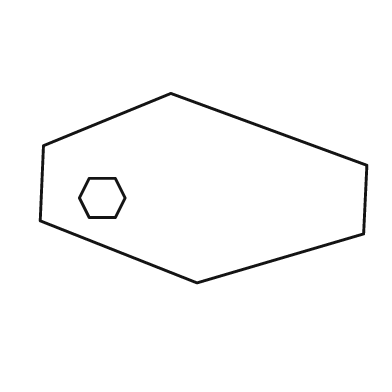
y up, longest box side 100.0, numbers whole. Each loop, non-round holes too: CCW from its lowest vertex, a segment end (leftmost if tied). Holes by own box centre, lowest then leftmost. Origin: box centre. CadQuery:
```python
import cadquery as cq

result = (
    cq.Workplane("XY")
    .moveTo(-2.0, -29.0)
    .lineTo(49.0, -14.0)
    .lineTo(50.0, 7.0)
    .lineTo(-10.0, 29.0)
    .lineTo(-49.0, 13.0)
    .lineTo(-50.0, -10.0)
    .close()
    .moveTo(-35.0, -9.0)
    .lineTo(-27.0, -9.0)
    .lineTo(-24.0, -3.0)
    .lineTo(-27.0, 3.0)
    .lineTo(-35.0, 3.0)
    .lineTo(-38.0, -3.0)
    .close()
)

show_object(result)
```